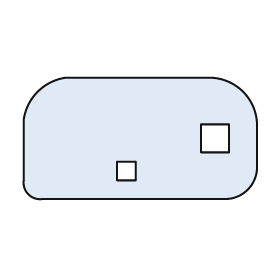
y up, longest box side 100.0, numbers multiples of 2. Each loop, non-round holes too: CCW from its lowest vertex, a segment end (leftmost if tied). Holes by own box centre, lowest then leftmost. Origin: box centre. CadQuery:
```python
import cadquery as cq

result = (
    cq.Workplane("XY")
    .moveTo(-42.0, -26.0)
    .lineTo(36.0, -26.0)
    .threePointArc((46.0, -22.0), (50.0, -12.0))
    .lineTo(50.0, 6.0)
    .threePointArc((44.0, 20.0), (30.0, 26.0))
    .lineTo(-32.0, 26.0)
    .threePointArc((-44.0, 20.0), (-50.0, 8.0))
    .lineTo(-50.0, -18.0)
    .threePointArc((-48.0, -24.0), (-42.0, -26.0))
    .close()
    .moveTo(-10.0, -18.0)
    .lineTo(-2.0, -18.0)
    .lineTo(-2.0, -10.0)
    .lineTo(-10.0, -10.0)
    .close()
    .moveTo(26.0, -6.0)
    .lineTo(38.0, -6.0)
    .lineTo(38.0, 6.0)
    .lineTo(26.0, 6.0)
    .close()
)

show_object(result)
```